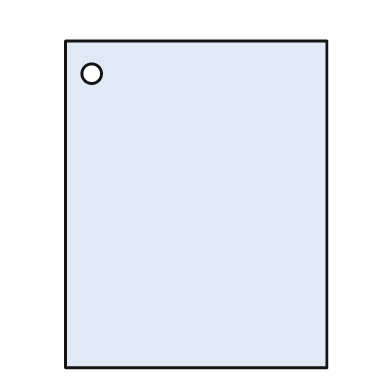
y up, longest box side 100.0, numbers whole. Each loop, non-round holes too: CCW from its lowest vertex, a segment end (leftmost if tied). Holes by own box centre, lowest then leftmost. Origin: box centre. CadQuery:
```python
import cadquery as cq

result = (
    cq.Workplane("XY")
    .moveTo(-40.0, -50.0)
    .lineTo(40.0, -50.0)
    .lineTo(40.0, 50.0)
    .lineTo(-40.0, 50.0)
    .close()
    .moveTo(-32.0, 40.0)
    .circle(3.0)
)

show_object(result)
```